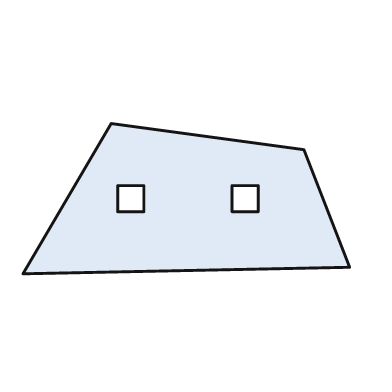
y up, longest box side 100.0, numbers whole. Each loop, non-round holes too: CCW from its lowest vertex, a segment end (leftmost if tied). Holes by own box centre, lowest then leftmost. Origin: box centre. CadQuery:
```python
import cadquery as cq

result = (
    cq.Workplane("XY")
    .moveTo(-50.0, -23.0)
    .lineTo(50.0, -21.0)
    .lineTo(36.0, 15.0)
    .lineTo(-23.0, 23.0)
    .close()
    .moveTo(-21.0, -4.0)
    .lineTo(-13.0, -4.0)
    .lineTo(-13.0, 4.0)
    .lineTo(-21.0, 4.0)
    .close()
    .moveTo(14.0, -4.0)
    .lineTo(22.0, -4.0)
    .lineTo(22.0, 4.0)
    .lineTo(14.0, 4.0)
    .close()
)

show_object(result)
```